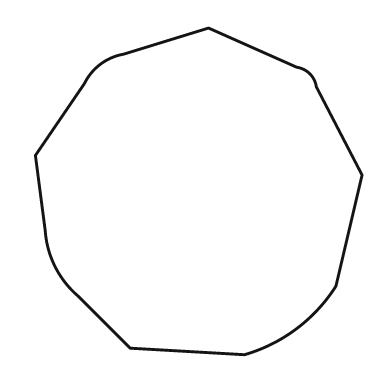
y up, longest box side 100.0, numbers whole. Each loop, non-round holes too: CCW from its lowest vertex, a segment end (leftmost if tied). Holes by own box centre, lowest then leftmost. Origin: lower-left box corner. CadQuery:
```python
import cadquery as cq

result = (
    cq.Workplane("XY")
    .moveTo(64.0, 0.0)
    .threePointArc((80.0, 8.0), (92.0, 21.0))
    .lineTo(100.0, 55.0)
    .lineTo(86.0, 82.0)
    .threePointArc((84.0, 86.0), (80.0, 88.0))
    .lineTo(53.0, 100.0)
    .lineTo(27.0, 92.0)
    .threePointArc((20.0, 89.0), (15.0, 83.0))
    .lineTo(0.0, 61.0)
    .lineTo(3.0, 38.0)
    .threePointArc((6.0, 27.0), (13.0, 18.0))
    .lineTo(29.0, 2.0)
    .close()
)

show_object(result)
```